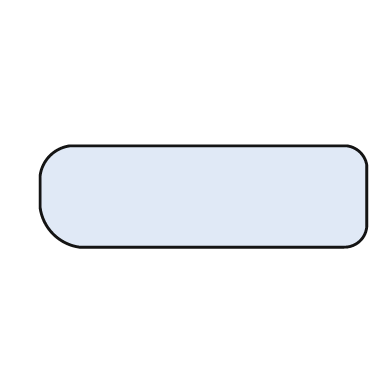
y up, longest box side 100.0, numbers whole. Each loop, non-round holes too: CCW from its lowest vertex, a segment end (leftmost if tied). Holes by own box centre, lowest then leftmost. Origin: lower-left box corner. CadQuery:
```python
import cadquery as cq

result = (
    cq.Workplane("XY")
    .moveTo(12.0, 0.0)
    .lineTo(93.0, 0.0)
    .threePointArc((98.0, 2.0), (100.0, 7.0))
    .lineTo(100.0, 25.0)
    .threePointArc((98.0, 29.0), (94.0, 31.0))
    .lineTo(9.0, 31.0)
    .threePointArc((3.0, 28.0), (0.0, 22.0))
    .lineTo(0.0, 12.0)
    .threePointArc((4.0, 4.0), (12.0, 0.0))
    .close()
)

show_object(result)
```